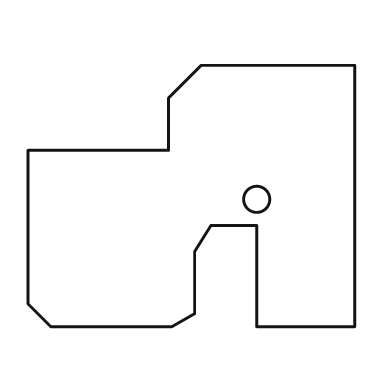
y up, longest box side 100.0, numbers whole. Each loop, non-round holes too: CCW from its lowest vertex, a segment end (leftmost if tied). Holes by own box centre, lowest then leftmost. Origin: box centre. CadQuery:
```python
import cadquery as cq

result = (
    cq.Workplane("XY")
    .moveTo(-43.0, -40.0)
    .lineTo(-6.0, -40.0)
    .lineTo(1.0, -36.0)
    .lineTo(1.0, -17.0)
    .lineTo(6.0, -9.0)
    .lineTo(20.0, -9.0)
    .lineTo(20.0, -40.0)
    .lineTo(50.0, -40.0)
    .lineTo(50.0, 40.0)
    .lineTo(3.0, 40.0)
    .lineTo(-7.0, 30.0)
    .lineTo(-7.0, 14.0)
    .lineTo(-50.0, 14.0)
    .lineTo(-50.0, -33.0)
    .close()
    .moveTo(20.0, -1.0)
    .circle(4.0)
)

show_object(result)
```